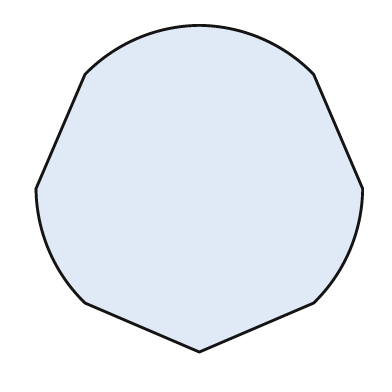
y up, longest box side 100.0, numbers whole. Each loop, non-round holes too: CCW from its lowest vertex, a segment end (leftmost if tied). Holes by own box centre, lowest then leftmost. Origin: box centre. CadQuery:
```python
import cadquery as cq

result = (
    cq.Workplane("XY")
    .moveTo(0.0, -50.0)
    .lineTo(35.0, -35.0)
    .threePointArc((46.0, -19.0), (50.0, 0.0))
    .lineTo(35.0, 35.0)
    .threePointArc((19.0, 46.0), (0.0, 50.0))
    .threePointArc((-19.0, 46.0), (-35.0, 35.0))
    .lineTo(-50.0, 0.0)
    .threePointArc((-46.0, -19.0), (-35.0, -35.0))
    .close()
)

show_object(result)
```